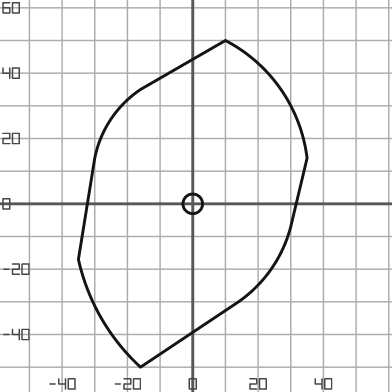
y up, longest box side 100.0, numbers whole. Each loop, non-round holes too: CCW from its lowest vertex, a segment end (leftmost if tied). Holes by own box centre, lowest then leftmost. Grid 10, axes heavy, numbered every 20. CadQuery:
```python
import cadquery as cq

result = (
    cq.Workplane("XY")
    .moveTo(-16.0, -50.0)
    .lineTo(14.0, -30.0)
    .threePointArc((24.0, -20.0), (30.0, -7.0))
    .lineTo(35.0, 14.0)
    .threePointArc((27.0, 35.0), (10.0, 50.0))
    .lineTo(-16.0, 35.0)
    .threePointArc((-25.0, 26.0), (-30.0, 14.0))
    .lineTo(-35.0, -17.0)
    .threePointArc((-28.0, -35.0), (-16.0, -50.0))
    .close()
    .moveTo(0.0, 0.0)
    .circle(3.0)
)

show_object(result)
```